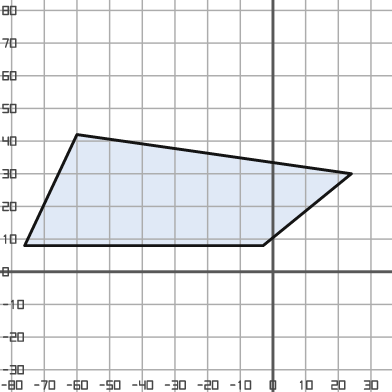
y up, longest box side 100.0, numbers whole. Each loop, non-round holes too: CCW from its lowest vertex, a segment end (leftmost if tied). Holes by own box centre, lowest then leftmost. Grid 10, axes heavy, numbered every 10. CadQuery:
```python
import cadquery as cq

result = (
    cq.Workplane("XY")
    .moveTo(-76.0, 8.0)
    .lineTo(-3.0, 8.0)
    .lineTo(24.0, 30.0)
    .lineTo(-60.0, 42.0)
    .close()
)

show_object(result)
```